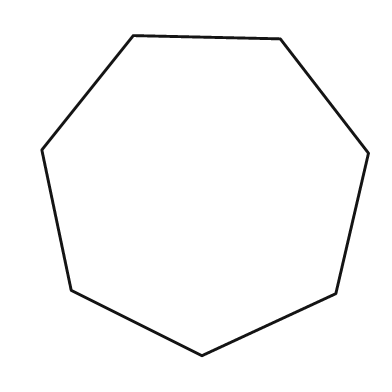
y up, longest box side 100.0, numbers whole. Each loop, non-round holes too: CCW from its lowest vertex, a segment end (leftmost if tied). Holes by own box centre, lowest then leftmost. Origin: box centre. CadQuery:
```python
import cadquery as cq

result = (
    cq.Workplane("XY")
    .moveTo(-1.0, -49.0)
    .lineTo(40.0, -30.0)
    .lineTo(50.0, 13.0)
    .lineTo(23.0, 48.0)
    .lineTo(-22.0, 49.0)
    .lineTo(-50.0, 14.0)
    .lineTo(-41.0, -29.0)
    .close()
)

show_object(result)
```